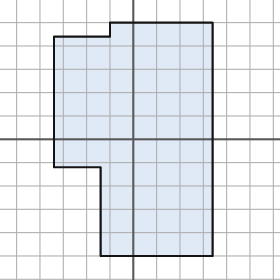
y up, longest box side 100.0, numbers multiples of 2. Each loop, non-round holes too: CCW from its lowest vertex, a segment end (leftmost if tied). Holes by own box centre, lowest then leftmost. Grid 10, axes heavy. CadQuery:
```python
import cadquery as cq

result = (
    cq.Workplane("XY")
    .moveTo(-14.0, -50.0)
    .lineTo(34.0, -50.0)
    .lineTo(34.0, 50.0)
    .lineTo(-10.0, 50.0)
    .lineTo(-10.0, 44.0)
    .lineTo(-34.0, 44.0)
    .lineTo(-34.0, -12.0)
    .lineTo(-14.0, -12.0)
    .close()
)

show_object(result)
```